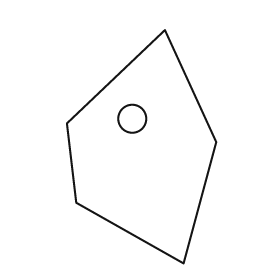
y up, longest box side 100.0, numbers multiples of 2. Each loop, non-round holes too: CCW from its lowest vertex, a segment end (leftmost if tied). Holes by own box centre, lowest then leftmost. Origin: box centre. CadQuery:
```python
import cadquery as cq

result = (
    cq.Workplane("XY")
    .moveTo(18.0, -50.0)
    .lineTo(32.0, 2.0)
    .lineTo(10.0, 50.0)
    .lineTo(-32.0, 10.0)
    .lineTo(-28.0, -24.0)
    .close()
    .moveTo(-4.0, 12.0)
    .circle(6.0)
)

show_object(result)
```